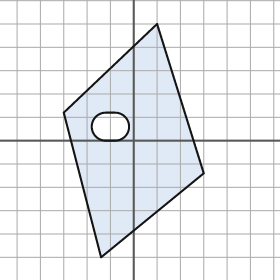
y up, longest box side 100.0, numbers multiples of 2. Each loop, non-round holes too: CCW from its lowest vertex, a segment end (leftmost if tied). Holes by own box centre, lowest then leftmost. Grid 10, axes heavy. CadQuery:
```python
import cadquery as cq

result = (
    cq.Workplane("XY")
    .moveTo(-14.0, -50.0)
    .lineTo(30.0, -14.0)
    .lineTo(10.0, 50.0)
    .lineTo(-30.0, 12.0)
    .close()
    .moveTo(-12.0, 0.0)
    .lineTo(-8.0, 0.0)
    .threePointArc((-2.0, 6.0), (-8.0, 12.0))
    .lineTo(-12.0, 12.0)
    .threePointArc((-18.0, 6.0), (-12.0, 0.0))
    .close()
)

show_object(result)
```